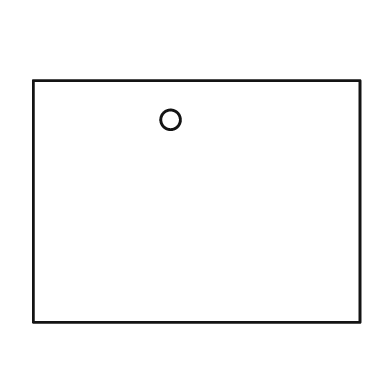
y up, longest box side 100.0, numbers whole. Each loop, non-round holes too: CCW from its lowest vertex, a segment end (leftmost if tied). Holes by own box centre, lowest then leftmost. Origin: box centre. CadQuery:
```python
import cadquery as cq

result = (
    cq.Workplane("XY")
    .moveTo(-50.0, -37.0)
    .lineTo(50.0, -37.0)
    .lineTo(50.0, 37.0)
    .lineTo(-50.0, 37.0)
    .close()
    .moveTo(-8.0, 25.0)
    .circle(3.0)
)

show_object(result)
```